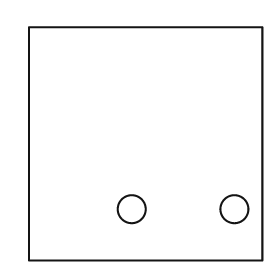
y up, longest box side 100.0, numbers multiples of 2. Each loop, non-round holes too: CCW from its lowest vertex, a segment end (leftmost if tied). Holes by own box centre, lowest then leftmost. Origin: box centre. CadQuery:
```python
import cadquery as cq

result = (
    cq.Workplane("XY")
    .moveTo(-50.0, -50.0)
    .lineTo(50.0, -50.0)
    .lineTo(50.0, 50.0)
    .lineTo(-50.0, 50.0)
    .close()
    .moveTo(-6.0, -28.0)
    .circle(6.0)
    .moveTo(38.0, -28.0)
    .circle(6.0)
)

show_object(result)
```